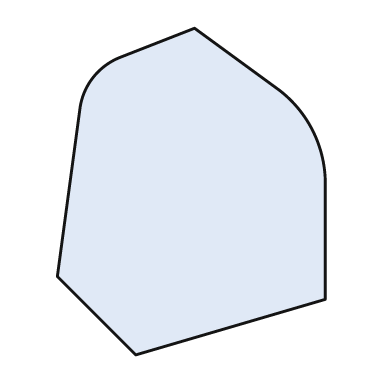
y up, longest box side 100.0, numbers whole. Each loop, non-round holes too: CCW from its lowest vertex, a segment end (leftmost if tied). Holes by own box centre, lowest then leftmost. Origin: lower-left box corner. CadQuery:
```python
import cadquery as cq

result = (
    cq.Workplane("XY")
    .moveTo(24.0, 0.0)
    .lineTo(82.0, 17.0)
    .lineTo(82.0, 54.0)
    .threePointArc((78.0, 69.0), (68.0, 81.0))
    .lineTo(42.0, 100.0)
    .lineTo(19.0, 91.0)
    .threePointArc((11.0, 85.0), (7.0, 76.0))
    .lineTo(0.0, 24.0)
    .close()
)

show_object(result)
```